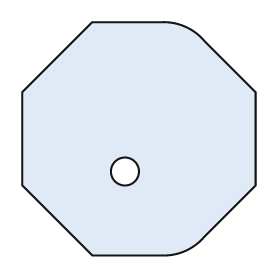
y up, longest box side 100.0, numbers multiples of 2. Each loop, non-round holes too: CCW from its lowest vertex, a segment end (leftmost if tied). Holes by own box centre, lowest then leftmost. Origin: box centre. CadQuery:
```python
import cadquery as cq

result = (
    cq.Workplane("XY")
    .moveTo(-20.0, -50.0)
    .lineTo(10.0, -50.0)
    .threePointArc((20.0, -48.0), (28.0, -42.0))
    .lineTo(50.0, -20.0)
    .lineTo(50.0, 20.0)
    .lineTo(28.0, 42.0)
    .threePointArc((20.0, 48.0), (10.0, 50.0))
    .lineTo(-20.0, 50.0)
    .lineTo(-50.0, 20.0)
    .lineTo(-50.0, -20.0)
    .close()
    .moveTo(-6.0, -14.0)
    .circle(6.0)
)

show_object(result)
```